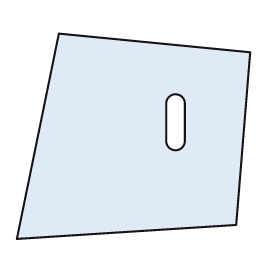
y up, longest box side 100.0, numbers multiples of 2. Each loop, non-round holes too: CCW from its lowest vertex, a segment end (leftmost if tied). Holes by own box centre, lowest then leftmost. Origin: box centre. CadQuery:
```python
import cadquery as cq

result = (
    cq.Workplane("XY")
    .moveTo(-50.0, -44.0)
    .lineTo(44.0, -38.0)
    .lineTo(50.0, 36.0)
    .lineTo(-32.0, 44.0)
    .close()
    .moveTo(14.0, -2.0)
    .threePointArc((18.0, -6.0), (22.0, -2.0))
    .lineTo(22.0, 14.0)
    .threePointArc((18.0, 18.0), (14.0, 14.0))
    .close()
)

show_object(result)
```